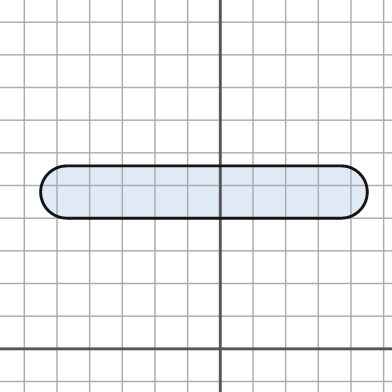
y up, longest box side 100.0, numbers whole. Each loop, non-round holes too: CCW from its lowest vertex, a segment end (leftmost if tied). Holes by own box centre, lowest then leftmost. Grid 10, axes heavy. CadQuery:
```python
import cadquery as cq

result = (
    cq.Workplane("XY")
    .moveTo(-47.0, 40.0)
    .lineTo(37.0, 40.0)
    .threePointArc((45.0, 48.0), (37.0, 56.0))
    .lineTo(-47.0, 56.0)
    .threePointArc((-55.0, 48.0), (-47.0, 40.0))
    .close()
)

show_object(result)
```